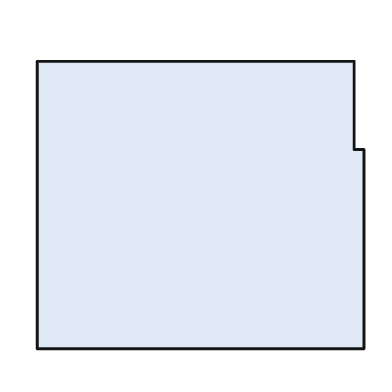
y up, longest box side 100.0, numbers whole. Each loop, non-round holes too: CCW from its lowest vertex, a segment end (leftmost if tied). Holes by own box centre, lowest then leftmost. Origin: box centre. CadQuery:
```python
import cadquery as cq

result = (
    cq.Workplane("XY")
    .moveTo(-50.0, -44.0)
    .lineTo(50.0, -44.0)
    .lineTo(50.0, 17.0)
    .lineTo(47.0, 17.0)
    .lineTo(47.0, 44.0)
    .lineTo(-50.0, 44.0)
    .close()
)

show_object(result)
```